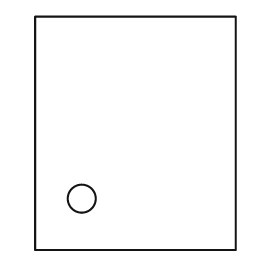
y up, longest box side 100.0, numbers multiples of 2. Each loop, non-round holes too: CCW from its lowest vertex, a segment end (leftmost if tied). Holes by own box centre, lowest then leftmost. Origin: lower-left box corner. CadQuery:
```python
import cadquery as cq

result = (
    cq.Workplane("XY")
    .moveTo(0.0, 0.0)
    .lineTo(86.0, 0.0)
    .lineTo(86.0, 100.0)
    .lineTo(0.0, 100.0)
    .close()
    .moveTo(20.0, 22.0)
    .circle(6.0)
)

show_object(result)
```